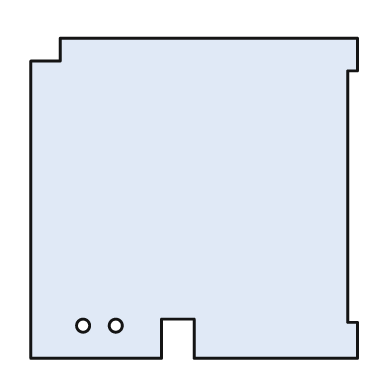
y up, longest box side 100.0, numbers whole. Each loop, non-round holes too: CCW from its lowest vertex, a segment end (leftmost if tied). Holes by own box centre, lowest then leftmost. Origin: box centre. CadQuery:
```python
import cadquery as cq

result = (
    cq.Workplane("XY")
    .moveTo(-50.0, -49.0)
    .lineTo(-10.0, -49.0)
    .lineTo(-10.0, -37.0)
    .lineTo(0.0, -37.0)
    .lineTo(0.0, -49.0)
    .lineTo(50.0, -49.0)
    .lineTo(50.0, -38.0)
    .lineTo(47.0, -38.0)
    .lineTo(47.0, 39.0)
    .lineTo(50.0, 39.0)
    .lineTo(50.0, 49.0)
    .lineTo(-41.0, 49.0)
    .lineTo(-41.0, 42.0)
    .lineTo(-50.0, 42.0)
    .close()
    .moveTo(-34.0, -39.0)
    .circle(2.0)
    .moveTo(-24.0, -39.0)
    .circle(2.0)
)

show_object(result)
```